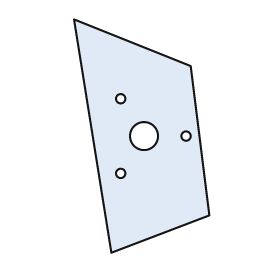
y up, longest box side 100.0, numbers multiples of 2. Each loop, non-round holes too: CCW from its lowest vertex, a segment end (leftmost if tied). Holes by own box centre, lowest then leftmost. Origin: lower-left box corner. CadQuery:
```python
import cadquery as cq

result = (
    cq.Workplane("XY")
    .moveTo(16.0, 0.0)
    .lineTo(58.0, 16.0)
    .lineTo(50.0, 80.0)
    .lineTo(0.0, 100.0)
    .close()
    .moveTo(20.0, 34.0)
    .circle(2.0)
    .moveTo(30.0, 50.0)
    .circle(6.0)
    .moveTo(48.0, 50.0)
    .circle(2.0)
    .moveTo(20.0, 66.0)
    .circle(2.0)
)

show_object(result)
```